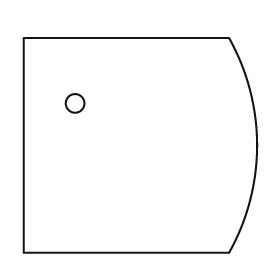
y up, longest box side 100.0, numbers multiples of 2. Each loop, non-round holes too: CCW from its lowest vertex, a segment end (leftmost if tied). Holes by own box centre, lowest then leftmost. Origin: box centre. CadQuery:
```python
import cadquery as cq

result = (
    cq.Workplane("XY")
    .moveTo(-50.0, -46.0)
    .lineTo(38.0, -46.0)
    .threePointArc((50.0, 0.0), (38.0, 46.0))
    .lineTo(-50.0, 46.0)
    .close()
    .moveTo(-28.0, 18.0)
    .circle(4.0)
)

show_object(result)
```